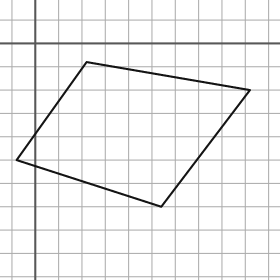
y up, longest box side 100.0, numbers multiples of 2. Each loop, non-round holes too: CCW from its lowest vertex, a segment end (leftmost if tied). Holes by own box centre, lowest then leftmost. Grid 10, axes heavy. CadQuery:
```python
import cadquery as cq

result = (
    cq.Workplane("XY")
    .moveTo(54.0, -70.0)
    .lineTo(92.0, -20.0)
    .lineTo(22.0, -8.0)
    .lineTo(-8.0, -50.0)
    .close()
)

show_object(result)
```